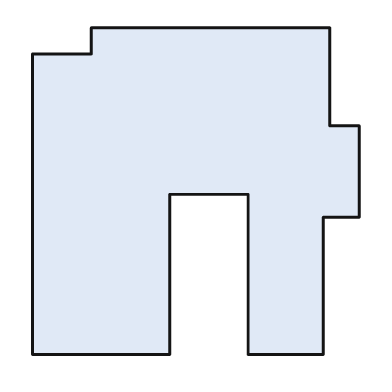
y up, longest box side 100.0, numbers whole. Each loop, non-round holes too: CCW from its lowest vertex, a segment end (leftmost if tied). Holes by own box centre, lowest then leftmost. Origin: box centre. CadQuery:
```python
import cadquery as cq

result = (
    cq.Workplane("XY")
    .moveTo(-50.0, -50.0)
    .lineTo(-8.0, -50.0)
    .lineTo(-8.0, -1.0)
    .lineTo(16.0, -1.0)
    .lineTo(16.0, -50.0)
    .lineTo(39.0, -50.0)
    .lineTo(39.0, -8.0)
    .lineTo(50.0, -8.0)
    .lineTo(50.0, 20.0)
    .lineTo(41.0, 20.0)
    .lineTo(41.0, 50.0)
    .lineTo(-32.0, 50.0)
    .lineTo(-32.0, 42.0)
    .lineTo(-50.0, 42.0)
    .close()
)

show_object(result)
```